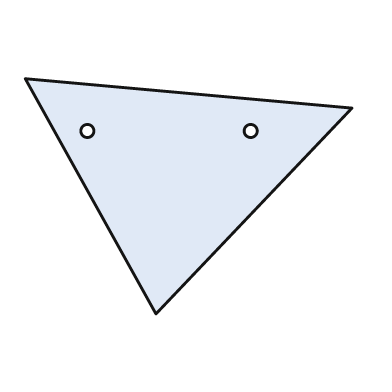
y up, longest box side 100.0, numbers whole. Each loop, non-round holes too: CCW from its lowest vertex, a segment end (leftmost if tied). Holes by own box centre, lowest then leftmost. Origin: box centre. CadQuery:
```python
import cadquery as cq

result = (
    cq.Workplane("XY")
    .moveTo(-10.0, -36.0)
    .lineTo(50.0, 27.0)
    .lineTo(-50.0, 36.0)
    .close()
    .moveTo(-31.0, 20.0)
    .circle(2.0)
    .moveTo(19.0, 20.0)
    .circle(2.0)
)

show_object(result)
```